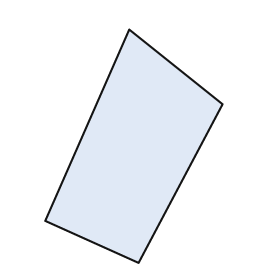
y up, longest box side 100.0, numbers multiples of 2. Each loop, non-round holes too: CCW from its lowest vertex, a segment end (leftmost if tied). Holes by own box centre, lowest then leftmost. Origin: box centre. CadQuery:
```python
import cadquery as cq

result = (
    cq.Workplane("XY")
    .moveTo(2.0, -50.0)
    .lineTo(38.0, 18.0)
    .lineTo(-2.0, 50.0)
    .lineTo(-38.0, -32.0)
    .close()
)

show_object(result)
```